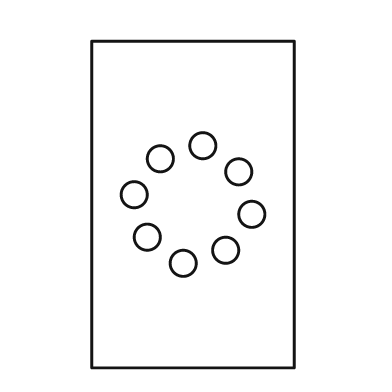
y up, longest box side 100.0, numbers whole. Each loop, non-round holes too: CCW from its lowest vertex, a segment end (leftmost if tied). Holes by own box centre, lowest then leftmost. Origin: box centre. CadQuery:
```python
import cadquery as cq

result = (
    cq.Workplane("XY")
    .moveTo(-31.0, -50.0)
    .lineTo(31.0, -50.0)
    .lineTo(31.0, 50.0)
    .lineTo(-31.0, 50.0)
    .close()
    .moveTo(-3.0, -18.0)
    .circle(4.0)
    .moveTo(10.0, -14.0)
    .circle(4.0)
    .moveTo(-14.0, -10.0)
    .circle(4.0)
    .moveTo(18.0, -3.0)
    .circle(4.0)
    .moveTo(-18.0, 3.0)
    .circle(4.0)
    .moveTo(14.0, 10.0)
    .circle(4.0)
    .moveTo(-10.0, 14.0)
    .circle(4.0)
    .moveTo(3.0, 18.0)
    .circle(4.0)
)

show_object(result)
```